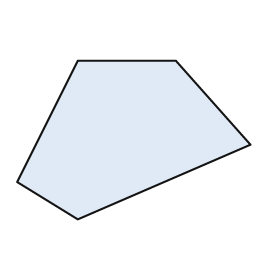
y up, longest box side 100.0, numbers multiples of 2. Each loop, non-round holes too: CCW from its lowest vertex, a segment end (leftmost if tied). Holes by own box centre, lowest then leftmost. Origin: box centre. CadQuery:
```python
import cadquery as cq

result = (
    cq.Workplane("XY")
    .moveTo(-24.0, -34.0)
    .lineTo(50.0, -2.0)
    .lineTo(18.0, 34.0)
    .lineTo(-24.0, 34.0)
    .lineTo(-50.0, -18.0)
    .close()
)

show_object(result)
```